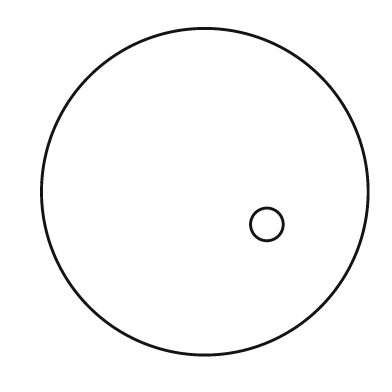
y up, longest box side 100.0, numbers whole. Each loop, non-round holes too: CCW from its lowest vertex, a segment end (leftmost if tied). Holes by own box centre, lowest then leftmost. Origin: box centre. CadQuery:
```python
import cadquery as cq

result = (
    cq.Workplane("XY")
    .moveTo(0.0, 0.0)
    .circle(50.0)
    .moveTo(19.0, -10.0)
    .circle(5.0)
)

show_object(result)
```